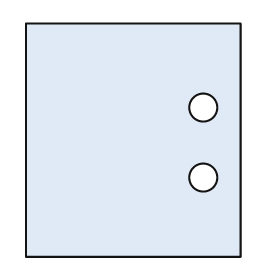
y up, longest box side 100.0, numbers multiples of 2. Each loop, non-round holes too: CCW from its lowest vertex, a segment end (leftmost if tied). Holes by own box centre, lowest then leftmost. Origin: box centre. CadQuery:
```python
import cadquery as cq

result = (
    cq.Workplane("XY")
    .moveTo(-46.0, -50.0)
    .lineTo(46.0, -50.0)
    .lineTo(46.0, 50.0)
    .lineTo(-46.0, 50.0)
    .close()
    .moveTo(30.0, -16.0)
    .circle(6.0)
    .moveTo(30.0, 14.0)
    .circle(6.0)
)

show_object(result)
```